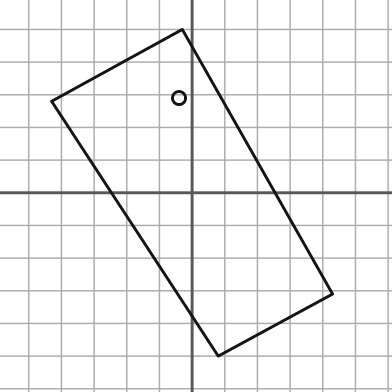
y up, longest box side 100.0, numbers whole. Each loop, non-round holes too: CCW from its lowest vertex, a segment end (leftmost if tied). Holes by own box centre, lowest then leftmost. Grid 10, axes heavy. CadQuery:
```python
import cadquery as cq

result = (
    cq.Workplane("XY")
    .moveTo(8.0, -50.0)
    .lineTo(43.0, -31.0)
    .lineTo(-3.0, 50.0)
    .lineTo(-43.0, 28.0)
    .close()
    .moveTo(-4.0, 29.0)
    .circle(2.0)
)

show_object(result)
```